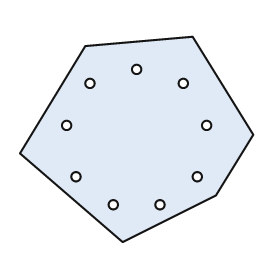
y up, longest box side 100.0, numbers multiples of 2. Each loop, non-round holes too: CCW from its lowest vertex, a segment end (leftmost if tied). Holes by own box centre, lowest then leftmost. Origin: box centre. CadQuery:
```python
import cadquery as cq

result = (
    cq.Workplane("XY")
    .moveTo(-6.0, -44.0)
    .lineTo(34.0, -24.0)
    .lineTo(50.0, 2.0)
    .lineTo(24.0, 44.0)
    .lineTo(-22.0, 40.0)
    .lineTo(-50.0, -6.0)
    .close()
    .moveTo(-10.0, -28.0)
    .circle(2.0)
    .moveTo(10.0, -28.0)
    .circle(2.0)
    .moveTo(-26.0, -16.0)
    .circle(2.0)
    .moveTo(26.0, -16.0)
    .circle(2.0)
    .moveTo(-30.0, 6.0)
    .circle(2.0)
    .moveTo(30.0, 6.0)
    .circle(2.0)
    .moveTo(-20.0, 24.0)
    .circle(2.0)
    .moveTo(20.0, 24.0)
    .circle(2.0)
    .moveTo(0.0, 30.0)
    .circle(2.0)
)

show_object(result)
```